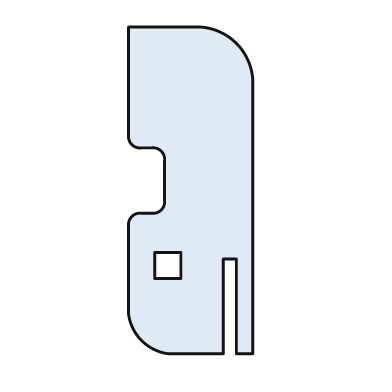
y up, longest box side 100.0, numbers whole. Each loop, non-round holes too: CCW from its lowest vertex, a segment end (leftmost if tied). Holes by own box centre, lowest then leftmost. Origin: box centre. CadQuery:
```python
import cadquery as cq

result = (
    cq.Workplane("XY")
    .moveTo(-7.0, -50.0)
    .lineTo(10.0, -50.0)
    .lineTo(10.0, -21.0)
    .lineTo(14.0, -21.0)
    .lineTo(14.0, -50.0)
    .lineTo(19.0, -50.0)
    .lineTo(19.0, 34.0)
    .threePointArc((14.0, 45.0), (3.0, 50.0))
    .lineTo(-19.0, 50.0)
    .lineTo(-19.0, 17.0)
    .threePointArc((-18.0, 14.0), (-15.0, 13.0))
    .lineTo(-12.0, 13.0)
    .threePointArc((-9.0, 12.0), (-8.0, 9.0))
    .lineTo(-8.0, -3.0)
    .threePointArc((-9.0, -6.0), (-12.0, -7.0))
    .lineTo(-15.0, -7.0)
    .threePointArc((-18.0, -8.0), (-19.0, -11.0))
    .lineTo(-19.0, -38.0)
    .threePointArc((-15.0, -46.0), (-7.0, -50.0))
    .close()
    .moveTo(-11.0, -27.0)
    .lineTo(-3.0, -27.0)
    .lineTo(-3.0, -19.0)
    .lineTo(-11.0, -19.0)
    .close()
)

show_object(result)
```